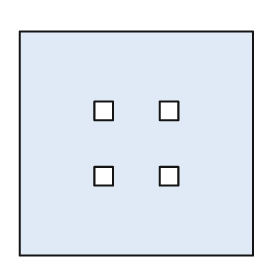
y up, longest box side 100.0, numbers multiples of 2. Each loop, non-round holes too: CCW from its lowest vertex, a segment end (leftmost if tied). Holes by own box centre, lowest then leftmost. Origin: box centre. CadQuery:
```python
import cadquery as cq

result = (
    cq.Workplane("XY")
    .moveTo(-50.0, -48.0)
    .lineTo(50.0, -48.0)
    .lineTo(50.0, 48.0)
    .lineTo(-50.0, 48.0)
    .close()
    .moveTo(-18.0, -18.0)
    .lineTo(-10.0, -18.0)
    .lineTo(-10.0, -10.0)
    .lineTo(-18.0, -10.0)
    .close()
    .moveTo(10.0, -18.0)
    .lineTo(18.0, -18.0)
    .lineTo(18.0, -10.0)
    .lineTo(10.0, -10.0)
    .close()
    .moveTo(-18.0, 10.0)
    .lineTo(-10.0, 10.0)
    .lineTo(-10.0, 18.0)
    .lineTo(-18.0, 18.0)
    .close()
    .moveTo(10.0, 10.0)
    .lineTo(18.0, 10.0)
    .lineTo(18.0, 18.0)
    .lineTo(10.0, 18.0)
    .close()
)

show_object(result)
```